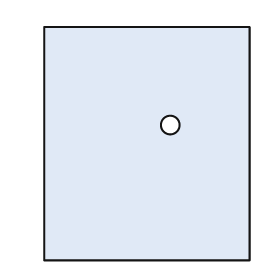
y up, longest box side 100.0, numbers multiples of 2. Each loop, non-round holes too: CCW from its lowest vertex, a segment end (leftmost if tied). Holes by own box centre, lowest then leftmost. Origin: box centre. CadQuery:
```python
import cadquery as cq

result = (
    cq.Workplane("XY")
    .moveTo(-44.0, -50.0)
    .lineTo(44.0, -50.0)
    .lineTo(44.0, 50.0)
    .lineTo(-44.0, 50.0)
    .close()
    .moveTo(10.0, 8.0)
    .circle(4.0)
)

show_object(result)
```